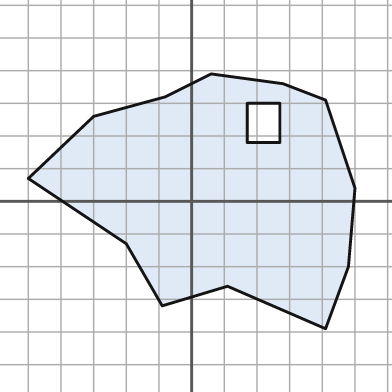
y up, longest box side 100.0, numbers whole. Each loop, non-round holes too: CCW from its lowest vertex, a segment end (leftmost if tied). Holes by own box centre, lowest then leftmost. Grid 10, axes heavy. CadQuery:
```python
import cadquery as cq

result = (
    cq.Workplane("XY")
    .moveTo(41.0, -39.0)
    .lineTo(48.0, -20.0)
    .lineTo(50.0, 4.0)
    .lineTo(41.0, 31.0)
    .lineTo(28.0, 36.0)
    .lineTo(6.0, 39.0)
    .lineTo(-8.0, 32.0)
    .lineTo(-30.0, 26.0)
    .lineTo(-50.0, 7.0)
    .lineTo(-20.0, -13.0)
    .lineTo(-9.0, -32.0)
    .lineTo(11.0, -26.0)
    .close()
    .moveTo(17.0, 18.0)
    .lineTo(27.0, 18.0)
    .lineTo(27.0, 30.0)
    .lineTo(17.0, 30.0)
    .close()
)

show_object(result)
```